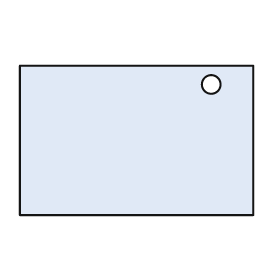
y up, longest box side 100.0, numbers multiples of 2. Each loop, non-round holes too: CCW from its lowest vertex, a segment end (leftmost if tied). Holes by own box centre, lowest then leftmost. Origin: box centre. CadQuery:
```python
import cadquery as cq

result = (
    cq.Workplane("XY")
    .moveTo(-50.0, -32.0)
    .lineTo(50.0, -32.0)
    .lineTo(50.0, 32.0)
    .lineTo(-50.0, 32.0)
    .close()
    .moveTo(32.0, 24.0)
    .circle(4.0)
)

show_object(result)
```